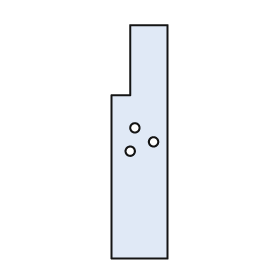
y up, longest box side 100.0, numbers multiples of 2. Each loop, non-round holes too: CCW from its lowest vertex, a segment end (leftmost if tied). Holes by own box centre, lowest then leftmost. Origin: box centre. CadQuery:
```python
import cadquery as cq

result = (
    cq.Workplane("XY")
    .moveTo(-12.0, -50.0)
    .lineTo(12.0, -50.0)
    .lineTo(12.0, 50.0)
    .lineTo(-4.0, 50.0)
    .lineTo(-4.0, 20.0)
    .lineTo(-12.0, 20.0)
    .close()
    .moveTo(-4.0, -4.0)
    .circle(2.0)
    .moveTo(6.0, 0.0)
    .circle(2.0)
    .moveTo(-2.0, 6.0)
    .circle(2.0)
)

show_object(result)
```